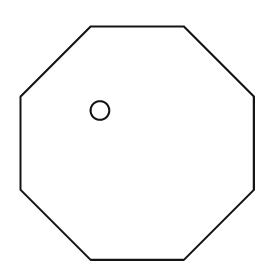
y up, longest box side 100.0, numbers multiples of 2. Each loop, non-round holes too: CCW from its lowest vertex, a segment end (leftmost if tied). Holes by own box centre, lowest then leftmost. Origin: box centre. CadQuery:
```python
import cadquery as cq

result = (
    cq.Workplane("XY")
    .moveTo(-20.0, -50.0)
    .lineTo(20.0, -50.0)
    .lineTo(50.0, -20.0)
    .lineTo(50.0, 20.0)
    .lineTo(20.0, 50.0)
    .lineTo(-20.0, 50.0)
    .lineTo(-50.0, 20.0)
    .lineTo(-50.0, -20.0)
    .close()
    .moveTo(-16.0, 14.0)
    .circle(4.0)
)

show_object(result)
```